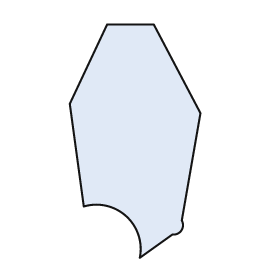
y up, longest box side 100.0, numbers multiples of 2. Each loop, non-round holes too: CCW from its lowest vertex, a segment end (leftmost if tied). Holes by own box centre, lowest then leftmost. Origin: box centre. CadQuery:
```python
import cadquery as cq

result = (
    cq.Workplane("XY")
    .moveTo(2.0, -50.0)
    .lineTo(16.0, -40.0)
    .threePointArc((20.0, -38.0), (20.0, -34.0))
    .lineTo(28.0, 12.0)
    .lineTo(8.0, 50.0)
    .lineTo(-12.0, 50.0)
    .lineTo(-28.0, 16.0)
    .lineTo(-22.0, -28.0)
    .threePointArc((-4.0, -32.0), (2.0, -50.0))
    .close()
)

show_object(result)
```